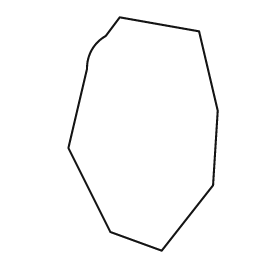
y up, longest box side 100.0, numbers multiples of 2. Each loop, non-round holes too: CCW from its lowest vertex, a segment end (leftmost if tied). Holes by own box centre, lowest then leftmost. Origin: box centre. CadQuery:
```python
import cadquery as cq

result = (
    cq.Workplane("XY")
    .moveTo(8.0, -50.0)
    .lineTo(30.0, -22.0)
    .lineTo(32.0, 10.0)
    .lineTo(24.0, 44.0)
    .lineTo(-10.0, 50.0)
    .lineTo(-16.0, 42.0)
    .threePointArc((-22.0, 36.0), (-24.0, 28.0))
    .lineTo(-32.0, -6.0)
    .lineTo(-14.0, -42.0)
    .close()
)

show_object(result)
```